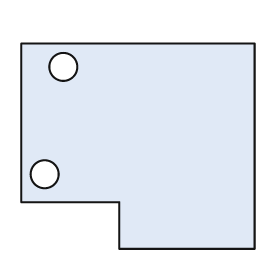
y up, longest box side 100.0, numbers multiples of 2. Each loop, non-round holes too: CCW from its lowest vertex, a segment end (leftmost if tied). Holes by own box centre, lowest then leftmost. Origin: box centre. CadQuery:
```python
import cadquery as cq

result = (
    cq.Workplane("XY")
    .moveTo(-8.0, -44.0)
    .lineTo(50.0, -44.0)
    .lineTo(50.0, 44.0)
    .lineTo(-50.0, 44.0)
    .lineTo(-50.0, -24.0)
    .lineTo(-8.0, -24.0)
    .close()
    .moveTo(-40.0, -12.0)
    .circle(6.0)
    .moveTo(-32.0, 34.0)
    .circle(6.0)
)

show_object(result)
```